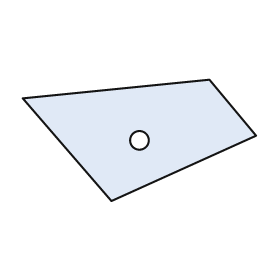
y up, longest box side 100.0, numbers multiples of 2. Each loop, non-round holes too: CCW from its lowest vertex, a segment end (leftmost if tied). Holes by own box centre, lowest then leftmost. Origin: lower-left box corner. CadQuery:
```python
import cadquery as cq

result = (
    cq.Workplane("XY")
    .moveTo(38.0, 0.0)
    .lineTo(100.0, 28.0)
    .lineTo(80.0, 52.0)
    .lineTo(0.0, 44.0)
    .close()
    .moveTo(50.0, 26.0)
    .circle(4.0)
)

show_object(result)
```